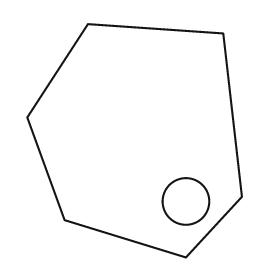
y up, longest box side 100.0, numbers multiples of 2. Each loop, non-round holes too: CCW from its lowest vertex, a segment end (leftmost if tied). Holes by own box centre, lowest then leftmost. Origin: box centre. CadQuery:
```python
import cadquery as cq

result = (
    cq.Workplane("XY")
    .moveTo(22.0, -50.0)
    .lineTo(46.0, -24.0)
    .lineTo(38.0, 46.0)
    .lineTo(-20.0, 50.0)
    .lineTo(-46.0, 10.0)
    .lineTo(-30.0, -34.0)
    .close()
    .moveTo(22.0, -26.0)
    .circle(10.0)
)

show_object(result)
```